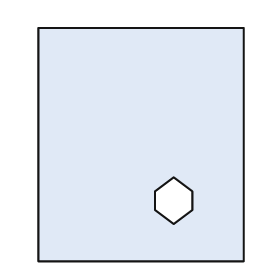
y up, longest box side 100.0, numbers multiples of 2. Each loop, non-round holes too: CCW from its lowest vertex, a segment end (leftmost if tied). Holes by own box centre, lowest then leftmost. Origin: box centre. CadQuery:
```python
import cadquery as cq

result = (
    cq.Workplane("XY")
    .moveTo(-44.0, -50.0)
    .lineTo(44.0, -50.0)
    .lineTo(44.0, 50.0)
    .lineTo(-44.0, 50.0)
    .close()
    .moveTo(14.0, -34.0)
    .lineTo(22.0, -28.0)
    .lineTo(22.0, -20.0)
    .lineTo(14.0, -14.0)
    .lineTo(6.0, -20.0)
    .lineTo(6.0, -28.0)
    .close()
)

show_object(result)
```